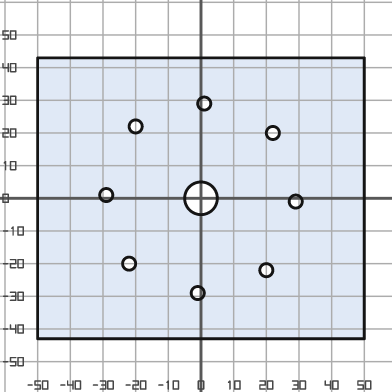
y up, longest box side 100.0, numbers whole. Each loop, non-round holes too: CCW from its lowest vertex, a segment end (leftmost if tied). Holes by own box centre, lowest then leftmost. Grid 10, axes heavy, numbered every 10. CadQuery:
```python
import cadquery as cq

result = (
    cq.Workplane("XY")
    .moveTo(-50.0, -43.0)
    .lineTo(50.0, -43.0)
    .lineTo(50.0, 43.0)
    .lineTo(-50.0, 43.0)
    .close()
    .moveTo(-1.0, -29.0)
    .circle(2.0)
    .moveTo(20.0, -22.0)
    .circle(2.0)
    .moveTo(-22.0, -20.0)
    .circle(2.0)
    .moveTo(29.0, -1.0)
    .circle(2.0)
    .moveTo(0.0, 0.0)
    .circle(5.0)
    .moveTo(-29.0, 1.0)
    .circle(2.0)
    .moveTo(22.0, 20.0)
    .circle(2.0)
    .moveTo(-20.0, 22.0)
    .circle(2.0)
    .moveTo(1.0, 29.0)
    .circle(2.0)
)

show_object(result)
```